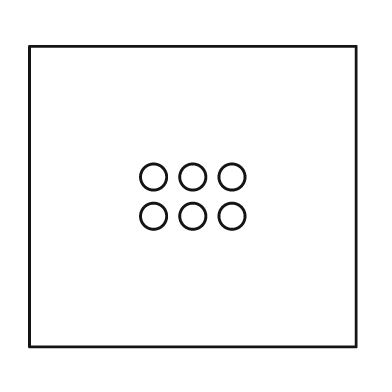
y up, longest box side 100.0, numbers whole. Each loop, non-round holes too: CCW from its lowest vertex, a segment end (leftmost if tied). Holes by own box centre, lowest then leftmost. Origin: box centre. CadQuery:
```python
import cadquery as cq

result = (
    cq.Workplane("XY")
    .moveTo(-50.0, -46.0)
    .lineTo(50.0, -46.0)
    .lineTo(50.0, 46.0)
    .lineTo(-50.0, 46.0)
    .close()
    .moveTo(-12.0, -6.0)
    .circle(4.0)
    .moveTo(0.0, -6.0)
    .circle(4.0)
    .moveTo(12.0, -6.0)
    .circle(4.0)
    .moveTo(-12.0, 6.0)
    .circle(4.0)
    .moveTo(0.0, 6.0)
    .circle(4.0)
    .moveTo(12.0, 6.0)
    .circle(4.0)
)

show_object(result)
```